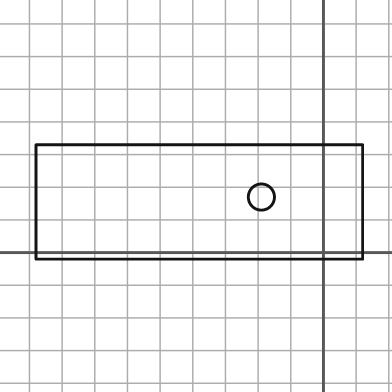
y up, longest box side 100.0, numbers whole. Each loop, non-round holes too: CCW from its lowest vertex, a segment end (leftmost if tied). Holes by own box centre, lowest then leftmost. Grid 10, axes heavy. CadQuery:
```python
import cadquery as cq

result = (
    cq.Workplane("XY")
    .moveTo(-88.0, -2.0)
    .lineTo(12.0, -2.0)
    .lineTo(12.0, 33.0)
    .lineTo(-88.0, 33.0)
    .close()
    .moveTo(-19.0, 17.0)
    .circle(4.0)
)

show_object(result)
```